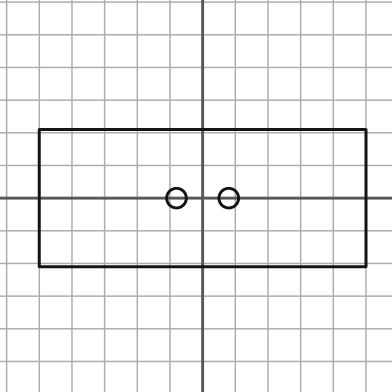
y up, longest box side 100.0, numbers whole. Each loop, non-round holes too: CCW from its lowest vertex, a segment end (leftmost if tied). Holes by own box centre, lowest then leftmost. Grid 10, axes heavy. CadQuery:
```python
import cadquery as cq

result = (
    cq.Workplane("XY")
    .moveTo(-50.0, -21.0)
    .lineTo(50.0, -21.0)
    .lineTo(50.0, 21.0)
    .lineTo(-50.0, 21.0)
    .close()
    .moveTo(-8.0, 0.0)
    .circle(3.0)
    .moveTo(8.0, 0.0)
    .circle(3.0)
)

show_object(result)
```